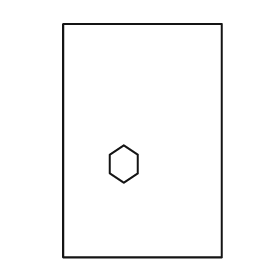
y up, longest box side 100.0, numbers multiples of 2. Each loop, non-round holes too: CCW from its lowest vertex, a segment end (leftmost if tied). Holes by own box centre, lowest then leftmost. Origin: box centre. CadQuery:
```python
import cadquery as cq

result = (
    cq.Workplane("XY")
    .moveTo(-34.0, -50.0)
    .lineTo(34.0, -50.0)
    .lineTo(34.0, 50.0)
    .lineTo(-34.0, 50.0)
    .close()
    .moveTo(-8.0, -18.0)
    .lineTo(-2.0, -14.0)
    .lineTo(-2.0, -6.0)
    .lineTo(-8.0, -2.0)
    .lineTo(-14.0, -6.0)
    .lineTo(-14.0, -14.0)
    .close()
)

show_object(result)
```